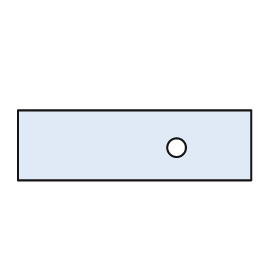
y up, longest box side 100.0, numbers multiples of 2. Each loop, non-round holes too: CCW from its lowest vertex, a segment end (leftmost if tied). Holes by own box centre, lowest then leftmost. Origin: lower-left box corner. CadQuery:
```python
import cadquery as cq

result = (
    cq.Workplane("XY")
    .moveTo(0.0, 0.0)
    .lineTo(100.0, 0.0)
    .lineTo(100.0, 30.0)
    .lineTo(0.0, 30.0)
    .close()
    .moveTo(68.0, 14.0)
    .circle(4.0)
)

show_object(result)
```